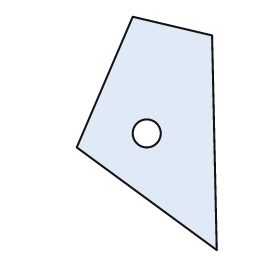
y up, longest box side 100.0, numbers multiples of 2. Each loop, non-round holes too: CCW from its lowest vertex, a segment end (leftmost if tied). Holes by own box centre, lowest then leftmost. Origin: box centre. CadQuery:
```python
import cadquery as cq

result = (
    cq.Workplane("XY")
    .moveTo(30.0, -50.0)
    .lineTo(28.0, 42.0)
    .lineTo(-6.0, 50.0)
    .lineTo(-30.0, -6.0)
    .close()
    .moveTo(0.0, 0.0)
    .circle(6.0)
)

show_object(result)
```